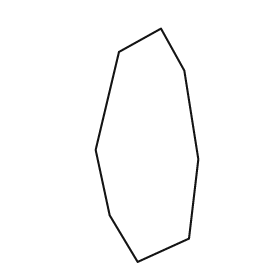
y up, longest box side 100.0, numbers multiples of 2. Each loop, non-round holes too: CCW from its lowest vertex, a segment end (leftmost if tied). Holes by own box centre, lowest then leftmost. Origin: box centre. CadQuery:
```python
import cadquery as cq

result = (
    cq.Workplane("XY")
    .moveTo(-4.0, -50.0)
    .lineTo(18.0, -40.0)
    .lineTo(22.0, -6.0)
    .lineTo(16.0, 32.0)
    .lineTo(6.0, 50.0)
    .lineTo(-12.0, 40.0)
    .lineTo(-22.0, -2.0)
    .lineTo(-16.0, -30.0)
    .close()
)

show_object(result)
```